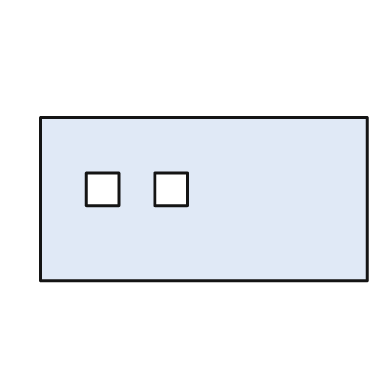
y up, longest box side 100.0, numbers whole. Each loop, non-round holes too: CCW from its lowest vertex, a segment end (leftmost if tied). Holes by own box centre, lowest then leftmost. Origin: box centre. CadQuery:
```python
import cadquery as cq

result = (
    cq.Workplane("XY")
    .moveTo(-50.0, -25.0)
    .lineTo(50.0, -25.0)
    .lineTo(50.0, 25.0)
    .lineTo(-50.0, 25.0)
    .close()
    .moveTo(-36.0, -2.0)
    .lineTo(-26.0, -2.0)
    .lineTo(-26.0, 8.0)
    .lineTo(-36.0, 8.0)
    .close()
    .moveTo(-15.0, -2.0)
    .lineTo(-5.0, -2.0)
    .lineTo(-5.0, 8.0)
    .lineTo(-15.0, 8.0)
    .close()
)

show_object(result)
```